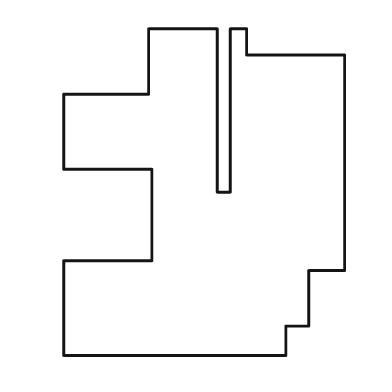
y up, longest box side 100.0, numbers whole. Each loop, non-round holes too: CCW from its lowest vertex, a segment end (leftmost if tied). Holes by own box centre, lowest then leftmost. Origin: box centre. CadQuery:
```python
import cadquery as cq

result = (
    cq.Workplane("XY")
    .moveTo(-43.0, -50.0)
    .lineTo(25.0, -50.0)
    .lineTo(25.0, -41.0)
    .lineTo(32.0, -41.0)
    .lineTo(32.0, -24.0)
    .lineTo(43.0, -24.0)
    .lineTo(43.0, 42.0)
    .lineTo(13.0, 42.0)
    .lineTo(13.0, 50.0)
    .lineTo(8.0, 50.0)
    .lineTo(8.0, 0.0)
    .lineTo(4.0, 0.0)
    .lineTo(4.0, 50.0)
    .lineTo(-17.0, 50.0)
    .lineTo(-17.0, 30.0)
    .lineTo(-43.0, 30.0)
    .lineTo(-43.0, 7.0)
    .lineTo(-16.0, 7.0)
    .lineTo(-16.0, -21.0)
    .lineTo(-43.0, -21.0)
    .close()
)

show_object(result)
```